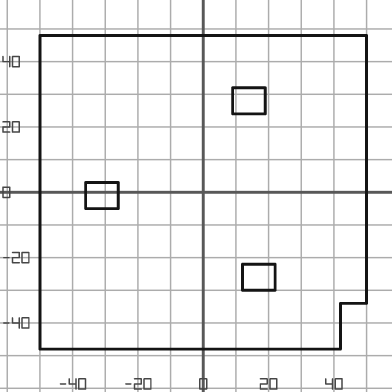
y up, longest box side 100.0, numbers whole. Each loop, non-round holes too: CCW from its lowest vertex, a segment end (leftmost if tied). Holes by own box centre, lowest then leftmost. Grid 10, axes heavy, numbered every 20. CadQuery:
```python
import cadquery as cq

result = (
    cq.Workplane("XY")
    .moveTo(-50.0, -48.0)
    .lineTo(42.0, -48.0)
    .lineTo(42.0, -34.0)
    .lineTo(50.0, -34.0)
    .lineTo(50.0, 48.0)
    .lineTo(-50.0, 48.0)
    .close()
    .moveTo(12.0, -30.0)
    .lineTo(22.0, -30.0)
    .lineTo(22.0, -22.0)
    .lineTo(12.0, -22.0)
    .close()
    .moveTo(-36.0, -5.0)
    .lineTo(-26.0, -5.0)
    .lineTo(-26.0, 3.0)
    .lineTo(-36.0, 3.0)
    .close()
    .moveTo(9.0, 24.0)
    .lineTo(19.0, 24.0)
    .lineTo(19.0, 32.0)
    .lineTo(9.0, 32.0)
    .close()
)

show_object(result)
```